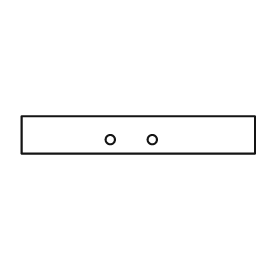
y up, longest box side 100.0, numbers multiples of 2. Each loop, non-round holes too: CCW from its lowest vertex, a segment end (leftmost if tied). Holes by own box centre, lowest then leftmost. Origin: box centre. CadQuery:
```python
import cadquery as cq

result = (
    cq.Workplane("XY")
    .moveTo(-50.0, -8.0)
    .lineTo(50.0, -8.0)
    .lineTo(50.0, 8.0)
    .lineTo(-50.0, 8.0)
    .close()
    .moveTo(-12.0, -2.0)
    .circle(2.0)
    .moveTo(6.0, -2.0)
    .circle(2.0)
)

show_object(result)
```